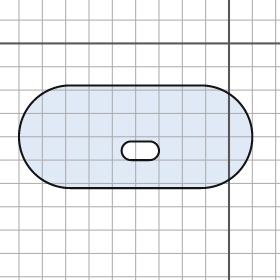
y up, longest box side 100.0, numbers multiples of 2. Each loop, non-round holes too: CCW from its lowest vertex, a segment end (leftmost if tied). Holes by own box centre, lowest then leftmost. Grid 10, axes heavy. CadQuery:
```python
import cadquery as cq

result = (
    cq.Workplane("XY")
    .moveTo(-68.0, -62.0)
    .lineTo(-12.0, -62.0)
    .threePointArc((10.0, -40.0), (-12.0, -18.0))
    .lineTo(-68.0, -18.0)
    .threePointArc((-90.0, -40.0), (-68.0, -62.0))
    .close()
    .moveTo(-42.0, -50.0)
    .lineTo(-34.0, -50.0)
    .threePointArc((-30.0, -46.0), (-34.0, -42.0))
    .lineTo(-42.0, -42.0)
    .threePointArc((-46.0, -46.0), (-42.0, -50.0))
    .close()
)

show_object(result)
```